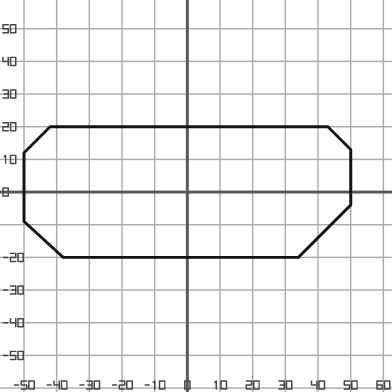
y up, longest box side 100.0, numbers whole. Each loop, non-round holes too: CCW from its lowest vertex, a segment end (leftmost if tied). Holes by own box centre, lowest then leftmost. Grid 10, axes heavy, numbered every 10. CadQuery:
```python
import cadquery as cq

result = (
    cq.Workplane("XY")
    .moveTo(-38.0, -20.0)
    .lineTo(34.0, -20.0)
    .lineTo(50.0, -4.0)
    .lineTo(50.0, 13.0)
    .lineTo(43.0, 20.0)
    .lineTo(-42.0, 20.0)
    .lineTo(-50.0, 12.0)
    .lineTo(-50.0, -9.0)
    .close()
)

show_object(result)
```